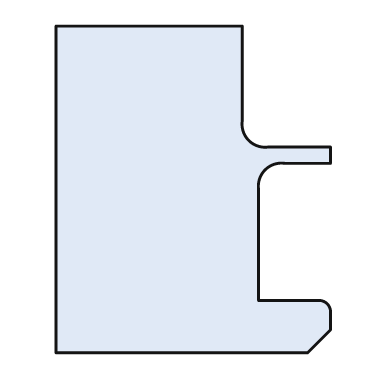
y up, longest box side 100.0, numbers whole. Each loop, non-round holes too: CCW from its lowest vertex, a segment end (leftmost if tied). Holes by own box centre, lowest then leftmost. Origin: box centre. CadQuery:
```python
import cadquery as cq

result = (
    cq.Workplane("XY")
    .moveTo(-42.0, -50.0)
    .lineTo(35.0, -50.0)
    .lineTo(42.0, -43.0)
    .lineTo(42.0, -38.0)
    .threePointArc((41.0, -35.0), (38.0, -34.0))
    .lineTo(20.0, -34.0)
    .lineTo(20.0, 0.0)
    .threePointArc((22.0, 6.0), (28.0, 8.0))
    .lineTo(42.0, 8.0)
    .lineTo(42.0, 13.0)
    .lineTo(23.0, 13.0)
    .threePointArc((17.0, 15.0), (15.0, 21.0))
    .lineTo(15.0, 50.0)
    .lineTo(-42.0, 50.0)
    .close()
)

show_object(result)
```